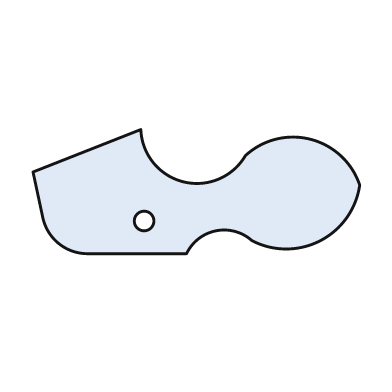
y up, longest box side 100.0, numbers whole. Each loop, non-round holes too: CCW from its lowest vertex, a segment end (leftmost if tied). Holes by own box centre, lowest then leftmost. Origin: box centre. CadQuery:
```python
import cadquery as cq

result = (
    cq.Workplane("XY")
    .moveTo(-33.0, -19.0)
    .lineTo(-3.0, -19.0)
    .threePointArc((6.0, -12.0), (17.0, -15.0))
    .threePointArc((38.0, -15.0), (50.0, 2.0))
    .threePointArc((35.0, 16.0), (15.0, 11.0))
    .threePointArc((-4.0, 3.0), (-17.0, 19.0))
    .lineTo(-50.0, 6.0)
    .lineTo(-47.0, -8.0)
    .threePointArc((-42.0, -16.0), (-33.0, -19.0))
    .close()
    .moveTo(-16.0, -9.0)
    .circle(3.0)
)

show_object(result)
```